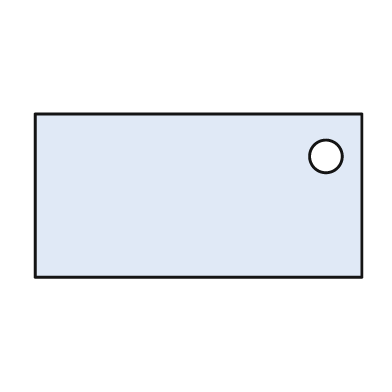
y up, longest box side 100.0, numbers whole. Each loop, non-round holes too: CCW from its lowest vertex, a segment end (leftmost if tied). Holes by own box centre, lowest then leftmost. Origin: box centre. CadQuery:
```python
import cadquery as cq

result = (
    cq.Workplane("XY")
    .moveTo(-50.0, -25.0)
    .lineTo(50.0, -25.0)
    .lineTo(50.0, 25.0)
    .lineTo(-50.0, 25.0)
    .close()
    .moveTo(39.0, 12.0)
    .circle(5.0)
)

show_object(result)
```